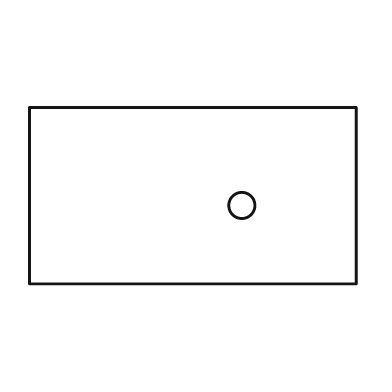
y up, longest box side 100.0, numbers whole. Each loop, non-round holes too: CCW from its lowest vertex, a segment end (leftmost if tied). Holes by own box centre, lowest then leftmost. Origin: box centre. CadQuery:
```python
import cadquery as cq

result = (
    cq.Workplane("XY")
    .moveTo(-50.0, -27.0)
    .lineTo(50.0, -27.0)
    .lineTo(50.0, 27.0)
    .lineTo(-50.0, 27.0)
    .close()
    .moveTo(15.0, -3.0)
    .circle(4.0)
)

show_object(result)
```